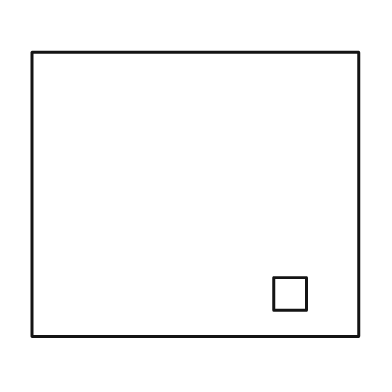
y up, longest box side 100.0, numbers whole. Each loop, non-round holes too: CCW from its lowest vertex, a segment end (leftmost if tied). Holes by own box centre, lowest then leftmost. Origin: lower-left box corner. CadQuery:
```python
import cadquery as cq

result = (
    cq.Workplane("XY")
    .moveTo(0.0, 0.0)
    .lineTo(100.0, 0.0)
    .lineTo(100.0, 87.0)
    .lineTo(0.0, 87.0)
    .close()
    .moveTo(74.0, 8.0)
    .lineTo(84.0, 8.0)
    .lineTo(84.0, 18.0)
    .lineTo(74.0, 18.0)
    .close()
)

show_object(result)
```